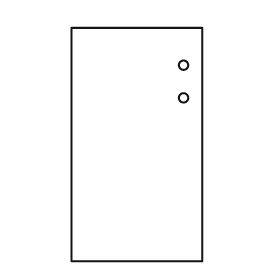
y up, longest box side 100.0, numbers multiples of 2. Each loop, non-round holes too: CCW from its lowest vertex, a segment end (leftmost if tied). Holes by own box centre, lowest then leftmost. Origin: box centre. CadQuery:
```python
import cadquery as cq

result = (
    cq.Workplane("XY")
    .moveTo(-28.0, -50.0)
    .lineTo(28.0, -50.0)
    .lineTo(28.0, 50.0)
    .lineTo(-28.0, 50.0)
    .close()
    .moveTo(20.0, 20.0)
    .circle(2.0)
    .moveTo(20.0, 34.0)
    .circle(2.0)
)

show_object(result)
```